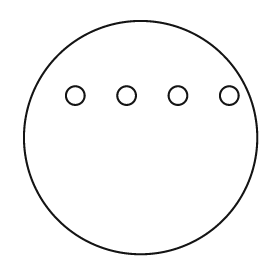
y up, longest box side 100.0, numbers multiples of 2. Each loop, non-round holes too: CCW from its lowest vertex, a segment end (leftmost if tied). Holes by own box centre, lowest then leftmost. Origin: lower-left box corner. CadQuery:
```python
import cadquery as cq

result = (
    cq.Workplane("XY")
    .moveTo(50.0, 50.0)
    .circle(50.0)
    .moveTo(22.0, 68.0)
    .circle(4.0)
    .moveTo(44.0, 68.0)
    .circle(4.0)
    .moveTo(66.0, 68.0)
    .circle(4.0)
    .moveTo(88.0, 68.0)
    .circle(4.0)
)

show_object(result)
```